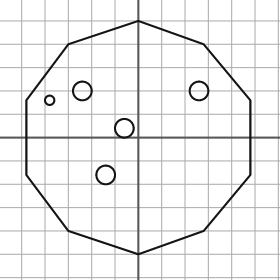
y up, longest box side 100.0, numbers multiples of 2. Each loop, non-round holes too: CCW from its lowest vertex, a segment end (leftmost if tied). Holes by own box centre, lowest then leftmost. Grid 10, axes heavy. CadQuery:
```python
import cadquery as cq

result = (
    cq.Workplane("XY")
    .moveTo(0.0, -50.0)
    .lineTo(28.0, -40.0)
    .lineTo(48.0, -16.0)
    .lineTo(48.0, 16.0)
    .lineTo(28.0, 40.0)
    .lineTo(0.0, 50.0)
    .lineTo(-30.0, 40.0)
    .lineTo(-48.0, 16.0)
    .lineTo(-48.0, -16.0)
    .lineTo(-30.0, -40.0)
    .close()
    .moveTo(-14.0, -16.0)
    .circle(4.0)
    .moveTo(-6.0, 4.0)
    .circle(4.0)
    .moveTo(-38.0, 16.0)
    .circle(2.0)
    .moveTo(-24.0, 20.0)
    .circle(4.0)
    .moveTo(26.0, 20.0)
    .circle(4.0)
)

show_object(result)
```